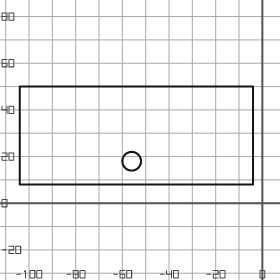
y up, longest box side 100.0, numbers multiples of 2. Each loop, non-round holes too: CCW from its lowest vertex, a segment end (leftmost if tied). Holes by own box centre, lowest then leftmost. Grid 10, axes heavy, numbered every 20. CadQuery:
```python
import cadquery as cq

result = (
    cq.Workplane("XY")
    .moveTo(-104.0, 8.0)
    .lineTo(-4.0, 8.0)
    .lineTo(-4.0, 50.0)
    .lineTo(-104.0, 50.0)
    .close()
    .moveTo(-56.0, 18.0)
    .circle(4.0)
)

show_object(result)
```